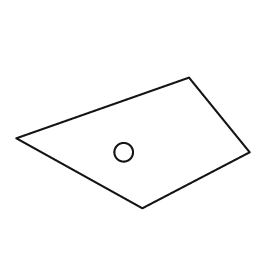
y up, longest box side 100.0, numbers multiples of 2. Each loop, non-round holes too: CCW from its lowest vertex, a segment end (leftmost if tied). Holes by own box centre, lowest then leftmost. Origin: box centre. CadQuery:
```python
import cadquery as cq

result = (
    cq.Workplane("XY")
    .moveTo(4.0, -28.0)
    .lineTo(50.0, -4.0)
    .lineTo(24.0, 28.0)
    .lineTo(-50.0, 2.0)
    .close()
    .moveTo(-4.0, -4.0)
    .circle(4.0)
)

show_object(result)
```